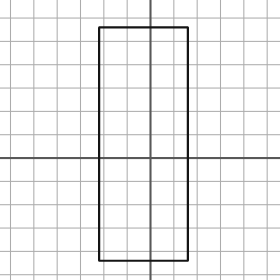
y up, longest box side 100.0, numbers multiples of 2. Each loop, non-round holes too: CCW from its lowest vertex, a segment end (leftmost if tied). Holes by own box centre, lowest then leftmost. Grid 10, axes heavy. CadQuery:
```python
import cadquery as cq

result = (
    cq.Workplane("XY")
    .moveTo(-22.0, -44.0)
    .lineTo(16.0, -44.0)
    .lineTo(16.0, 56.0)
    .lineTo(-22.0, 56.0)
    .close()
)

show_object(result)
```